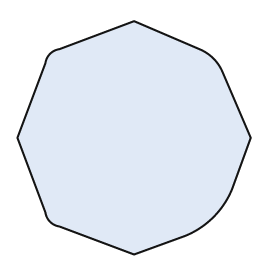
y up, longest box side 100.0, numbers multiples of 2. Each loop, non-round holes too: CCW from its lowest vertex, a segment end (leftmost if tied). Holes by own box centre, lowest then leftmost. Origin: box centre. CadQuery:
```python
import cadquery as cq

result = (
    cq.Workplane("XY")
    .moveTo(0.0, -50.0)
    .lineTo(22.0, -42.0)
    .threePointArc((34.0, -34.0), (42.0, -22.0))
    .lineTo(50.0, 0.0)
    .lineTo(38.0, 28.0)
    .threePointArc((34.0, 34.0), (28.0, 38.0))
    .lineTo(0.0, 50.0)
    .lineTo(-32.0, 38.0)
    .threePointArc((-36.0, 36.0), (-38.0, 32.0))
    .lineTo(-50.0, 0.0)
    .lineTo(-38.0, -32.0)
    .threePointArc((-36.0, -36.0), (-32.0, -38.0))
    .close()
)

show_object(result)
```